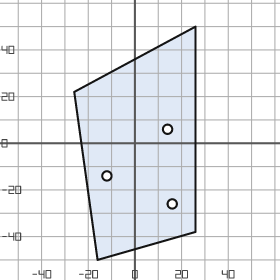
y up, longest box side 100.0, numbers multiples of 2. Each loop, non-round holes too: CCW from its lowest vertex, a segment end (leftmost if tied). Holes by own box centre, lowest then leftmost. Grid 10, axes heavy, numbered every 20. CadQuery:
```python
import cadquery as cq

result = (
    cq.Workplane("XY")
    .moveTo(-16.0, -50.0)
    .lineTo(26.0, -38.0)
    .lineTo(26.0, 50.0)
    .lineTo(-26.0, 22.0)
    .close()
    .moveTo(16.0, -26.0)
    .circle(2.0)
    .moveTo(-12.0, -14.0)
    .circle(2.0)
    .moveTo(14.0, 6.0)
    .circle(2.0)
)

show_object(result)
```